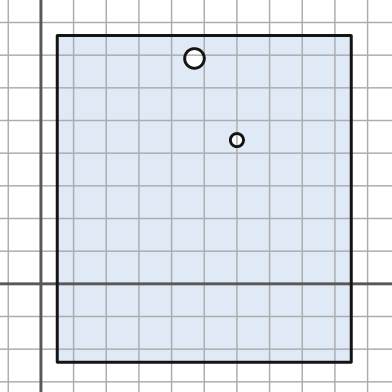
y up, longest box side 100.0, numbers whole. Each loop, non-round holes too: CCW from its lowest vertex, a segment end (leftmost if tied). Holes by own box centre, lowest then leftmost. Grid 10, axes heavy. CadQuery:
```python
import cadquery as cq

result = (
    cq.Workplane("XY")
    .moveTo(5.0, -24.0)
    .lineTo(95.0, -24.0)
    .lineTo(95.0, 76.0)
    .lineTo(5.0, 76.0)
    .close()
    .moveTo(60.0, 44.0)
    .circle(2.0)
    .moveTo(47.0, 69.0)
    .circle(3.0)
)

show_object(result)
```